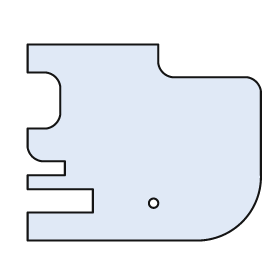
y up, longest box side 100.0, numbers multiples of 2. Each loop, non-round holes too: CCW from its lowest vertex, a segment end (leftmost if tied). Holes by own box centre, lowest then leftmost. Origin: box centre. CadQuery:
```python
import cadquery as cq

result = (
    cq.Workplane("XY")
    .moveTo(-50.0, -42.0)
    .lineTo(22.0, -42.0)
    .threePointArc((42.0, -34.0), (50.0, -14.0))
    .lineTo(50.0, 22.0)
    .threePointArc((48.0, 26.0), (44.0, 28.0))
    .lineTo(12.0, 28.0)
    .threePointArc((8.0, 30.0), (6.0, 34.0))
    .lineTo(6.0, 42.0)
    .lineTo(-50.0, 42.0)
    .lineTo(-50.0, 30.0)
    .lineTo(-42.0, 30.0)
    .threePointArc((-38.0, 28.0), (-36.0, 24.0))
    .lineTo(-36.0, 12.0)
    .threePointArc((-38.0, 8.0), (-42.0, 6.0))
    .lineTo(-50.0, 6.0)
    .lineTo(-50.0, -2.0)
    .threePointArc((-48.0, -6.0), (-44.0, -8.0))
    .lineTo(-34.0, -8.0)
    .lineTo(-34.0, -14.0)
    .lineTo(-50.0, -14.0)
    .lineTo(-50.0, -20.0)
    .lineTo(-22.0, -20.0)
    .lineTo(-22.0, -30.0)
    .lineTo(-50.0, -30.0)
    .close()
    .moveTo(4.0, -26.0)
    .circle(2.0)
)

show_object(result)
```